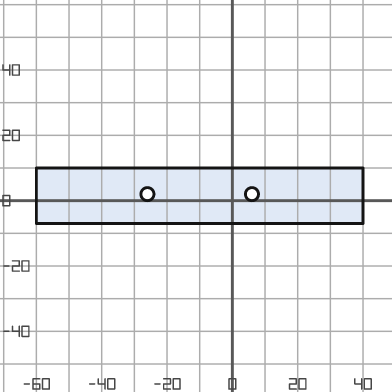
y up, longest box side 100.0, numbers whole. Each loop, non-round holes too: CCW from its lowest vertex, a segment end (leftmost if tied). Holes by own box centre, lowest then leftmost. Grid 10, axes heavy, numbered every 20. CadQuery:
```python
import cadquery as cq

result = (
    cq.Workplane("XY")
    .moveTo(-60.0, -7.0)
    .lineTo(40.0, -7.0)
    .lineTo(40.0, 10.0)
    .lineTo(-60.0, 10.0)
    .close()
    .moveTo(-26.0, 2.0)
    .circle(2.0)
    .moveTo(6.0, 2.0)
    .circle(2.0)
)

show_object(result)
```